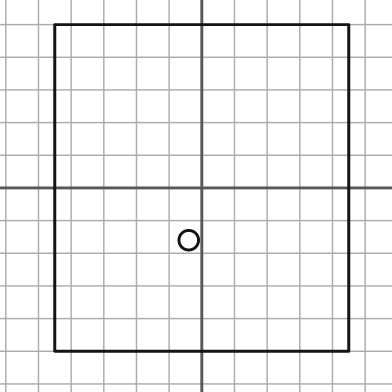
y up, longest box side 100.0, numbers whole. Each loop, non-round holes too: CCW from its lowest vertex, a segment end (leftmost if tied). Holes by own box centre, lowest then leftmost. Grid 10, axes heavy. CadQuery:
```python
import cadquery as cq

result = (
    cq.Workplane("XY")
    .moveTo(-45.0, -50.0)
    .lineTo(45.0, -50.0)
    .lineTo(45.0, 50.0)
    .lineTo(-45.0, 50.0)
    .close()
    .moveTo(-4.0, -16.0)
    .circle(3.0)
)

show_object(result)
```